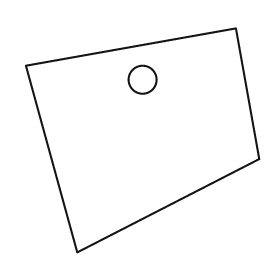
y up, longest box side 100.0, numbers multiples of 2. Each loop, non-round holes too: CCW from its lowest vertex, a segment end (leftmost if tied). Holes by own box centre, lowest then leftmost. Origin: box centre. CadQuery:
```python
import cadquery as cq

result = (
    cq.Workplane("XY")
    .moveTo(-28.0, -48.0)
    .lineTo(50.0, -8.0)
    .lineTo(40.0, 48.0)
    .lineTo(-50.0, 32.0)
    .close()
    .moveTo(0.0, 26.0)
    .circle(6.0)
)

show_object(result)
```